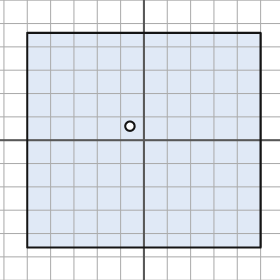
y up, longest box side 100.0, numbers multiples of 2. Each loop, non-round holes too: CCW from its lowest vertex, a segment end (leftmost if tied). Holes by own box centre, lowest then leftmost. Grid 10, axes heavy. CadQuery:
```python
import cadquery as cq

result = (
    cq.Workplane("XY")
    .moveTo(-50.0, -46.0)
    .lineTo(50.0, -46.0)
    .lineTo(50.0, 46.0)
    .lineTo(-50.0, 46.0)
    .close()
    .moveTo(-6.0, 6.0)
    .circle(2.0)
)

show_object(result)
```